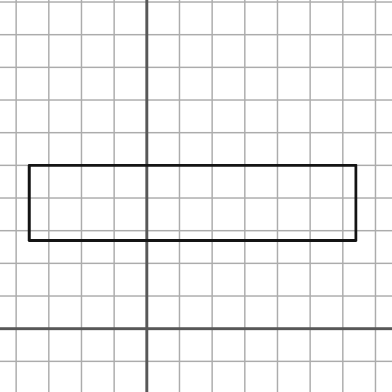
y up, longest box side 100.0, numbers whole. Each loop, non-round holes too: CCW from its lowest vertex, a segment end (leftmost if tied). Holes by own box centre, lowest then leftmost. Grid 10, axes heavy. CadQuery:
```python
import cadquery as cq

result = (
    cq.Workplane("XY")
    .moveTo(-36.0, 27.0)
    .lineTo(64.0, 27.0)
    .lineTo(64.0, 50.0)
    .lineTo(-36.0, 50.0)
    .close()
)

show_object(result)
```